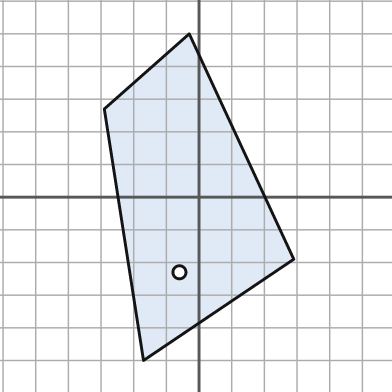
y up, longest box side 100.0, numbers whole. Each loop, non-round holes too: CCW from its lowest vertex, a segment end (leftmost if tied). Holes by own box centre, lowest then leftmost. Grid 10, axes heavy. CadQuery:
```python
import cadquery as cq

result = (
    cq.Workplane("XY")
    .moveTo(-17.0, -50.0)
    .lineTo(29.0, -19.0)
    .lineTo(-3.0, 50.0)
    .lineTo(-29.0, 27.0)
    .close()
    .moveTo(-6.0, -23.0)
    .circle(2.0)
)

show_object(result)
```